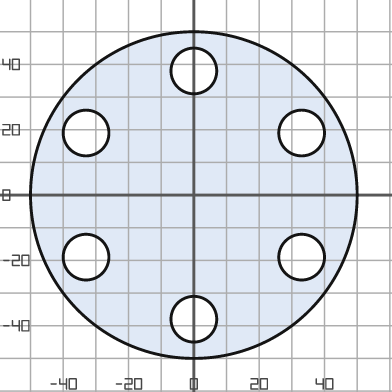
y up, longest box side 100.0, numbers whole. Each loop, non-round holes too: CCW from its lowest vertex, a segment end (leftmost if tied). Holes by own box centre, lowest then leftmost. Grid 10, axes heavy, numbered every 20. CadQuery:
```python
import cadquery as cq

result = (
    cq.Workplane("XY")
    .moveTo(0.0, 0.0)
    .circle(50.0)
    .moveTo(0.0, -38.0)
    .circle(7.0)
    .moveTo(-33.0, -19.0)
    .circle(7.0)
    .moveTo(33.0, -19.0)
    .circle(7.0)
    .moveTo(-33.0, 19.0)
    .circle(7.0)
    .moveTo(33.0, 19.0)
    .circle(7.0)
    .moveTo(0.0, 38.0)
    .circle(7.0)
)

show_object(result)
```